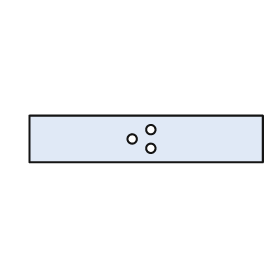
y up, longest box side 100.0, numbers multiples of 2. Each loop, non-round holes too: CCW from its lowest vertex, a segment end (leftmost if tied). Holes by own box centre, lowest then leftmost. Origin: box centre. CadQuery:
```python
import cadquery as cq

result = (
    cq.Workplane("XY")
    .moveTo(-50.0, -10.0)
    .lineTo(50.0, -10.0)
    .lineTo(50.0, 10.0)
    .lineTo(-50.0, 10.0)
    .close()
    .moveTo(2.0, -4.0)
    .circle(2.0)
    .moveTo(-6.0, 0.0)
    .circle(2.0)
    .moveTo(2.0, 4.0)
    .circle(2.0)
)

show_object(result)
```